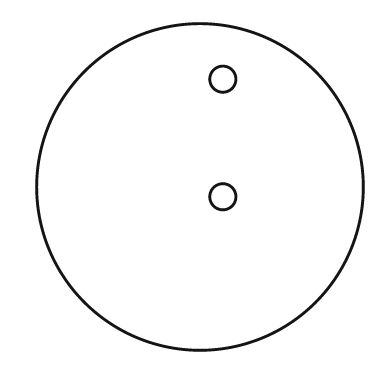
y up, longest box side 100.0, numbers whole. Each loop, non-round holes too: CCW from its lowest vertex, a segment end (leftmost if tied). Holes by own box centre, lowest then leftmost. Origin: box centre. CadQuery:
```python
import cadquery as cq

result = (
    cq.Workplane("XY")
    .moveTo(0.0, 0.0)
    .circle(50.0)
    .moveTo(7.0, -3.0)
    .circle(4.0)
    .moveTo(7.0, 33.0)
    .circle(4.0)
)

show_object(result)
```